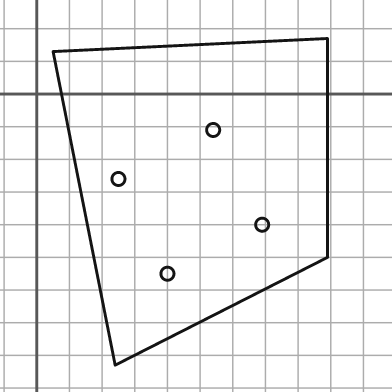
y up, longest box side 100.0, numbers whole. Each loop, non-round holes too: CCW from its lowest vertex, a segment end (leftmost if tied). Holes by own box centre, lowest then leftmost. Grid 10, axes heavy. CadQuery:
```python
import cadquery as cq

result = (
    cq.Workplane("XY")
    .moveTo(24.0, -83.0)
    .lineTo(89.0, -50.0)
    .lineTo(89.0, 17.0)
    .lineTo(5.0, 13.0)
    .close()
    .moveTo(40.0, -55.0)
    .circle(2.0)
    .moveTo(69.0, -40.0)
    .circle(2.0)
    .moveTo(25.0, -26.0)
    .circle(2.0)
    .moveTo(54.0, -11.0)
    .circle(2.0)
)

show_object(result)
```